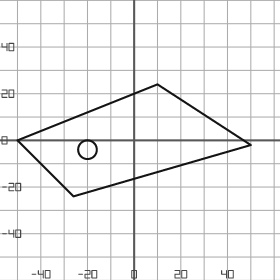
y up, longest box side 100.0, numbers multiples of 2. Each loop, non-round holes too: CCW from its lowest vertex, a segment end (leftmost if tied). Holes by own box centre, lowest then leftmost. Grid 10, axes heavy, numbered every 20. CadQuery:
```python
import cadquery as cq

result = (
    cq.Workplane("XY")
    .moveTo(-26.0, -24.0)
    .lineTo(50.0, -2.0)
    .lineTo(10.0, 24.0)
    .lineTo(-50.0, 0.0)
    .close()
    .moveTo(-20.0, -4.0)
    .circle(4.0)
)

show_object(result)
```